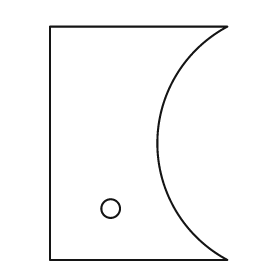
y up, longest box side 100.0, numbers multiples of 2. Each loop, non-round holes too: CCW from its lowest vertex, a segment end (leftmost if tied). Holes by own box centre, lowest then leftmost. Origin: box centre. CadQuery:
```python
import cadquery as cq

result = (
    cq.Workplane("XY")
    .moveTo(-38.0, -50.0)
    .lineTo(38.0, -50.0)
    .threePointArc((8.0, 0.0), (38.0, 50.0))
    .lineTo(-38.0, 50.0)
    .close()
    .moveTo(-12.0, -28.0)
    .circle(4.0)
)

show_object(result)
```